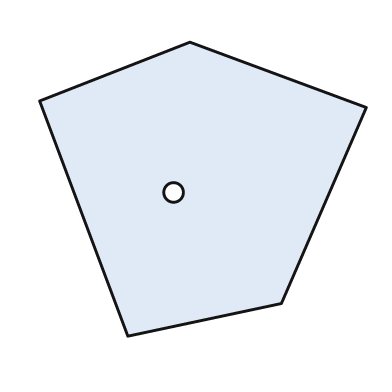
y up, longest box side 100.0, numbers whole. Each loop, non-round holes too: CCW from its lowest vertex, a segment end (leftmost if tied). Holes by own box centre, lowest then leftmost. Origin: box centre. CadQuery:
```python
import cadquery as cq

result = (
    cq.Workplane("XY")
    .moveTo(-23.0, -45.0)
    .lineTo(24.0, -35.0)
    .lineTo(50.0, 25.0)
    .lineTo(-4.0, 45.0)
    .lineTo(-50.0, 27.0)
    .close()
    .moveTo(-9.0, -1.0)
    .circle(3.0)
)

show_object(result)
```